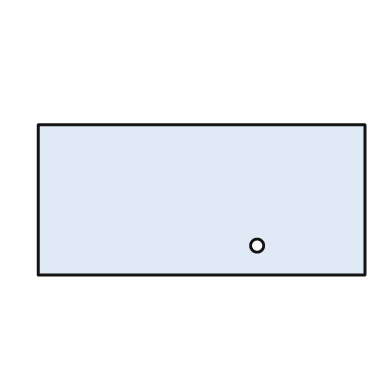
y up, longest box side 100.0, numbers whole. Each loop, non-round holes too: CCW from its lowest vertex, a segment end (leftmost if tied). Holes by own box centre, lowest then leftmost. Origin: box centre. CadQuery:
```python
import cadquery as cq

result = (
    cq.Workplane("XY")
    .moveTo(-50.0, -23.0)
    .lineTo(50.0, -23.0)
    .lineTo(50.0, 23.0)
    .lineTo(-50.0, 23.0)
    .close()
    .moveTo(17.0, -14.0)
    .circle(2.0)
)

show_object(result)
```